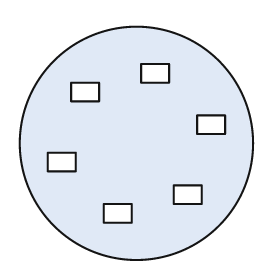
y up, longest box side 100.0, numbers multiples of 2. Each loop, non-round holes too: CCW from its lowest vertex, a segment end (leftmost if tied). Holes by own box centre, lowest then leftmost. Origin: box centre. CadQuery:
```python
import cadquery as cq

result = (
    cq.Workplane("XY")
    .moveTo(0.0, 0.0)
    .circle(50.0)
    .moveTo(-14.0, -34.0)
    .lineTo(-2.0, -34.0)
    .lineTo(-2.0, -26.0)
    .lineTo(-14.0, -26.0)
    .close()
    .moveTo(16.0, -26.0)
    .lineTo(28.0, -26.0)
    .lineTo(28.0, -18.0)
    .lineTo(16.0, -18.0)
    .close()
    .moveTo(-38.0, -12.0)
    .lineTo(-26.0, -12.0)
    .lineTo(-26.0, -4.0)
    .lineTo(-38.0, -4.0)
    .close()
    .moveTo(26.0, 4.0)
    .lineTo(38.0, 4.0)
    .lineTo(38.0, 12.0)
    .lineTo(26.0, 12.0)
    .close()
    .moveTo(-28.0, 18.0)
    .lineTo(-16.0, 18.0)
    .lineTo(-16.0, 26.0)
    .lineTo(-28.0, 26.0)
    .close()
    .moveTo(2.0, 26.0)
    .lineTo(14.0, 26.0)
    .lineTo(14.0, 34.0)
    .lineTo(2.0, 34.0)
    .close()
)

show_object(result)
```